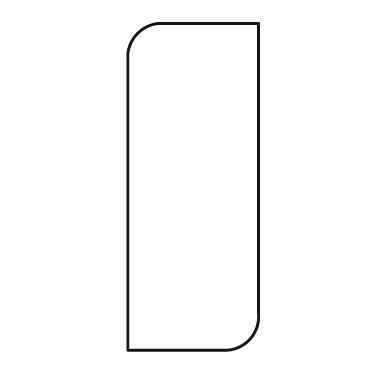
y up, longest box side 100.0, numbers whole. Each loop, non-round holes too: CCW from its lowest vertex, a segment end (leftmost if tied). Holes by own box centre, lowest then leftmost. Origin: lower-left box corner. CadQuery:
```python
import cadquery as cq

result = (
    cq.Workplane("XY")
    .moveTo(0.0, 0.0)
    .lineTo(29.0, 0.0)
    .threePointArc((37.0, 3.0), (40.0, 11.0))
    .lineTo(40.0, 100.0)
    .lineTo(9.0, 100.0)
    .threePointArc((3.0, 97.0), (0.0, 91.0))
    .close()
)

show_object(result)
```